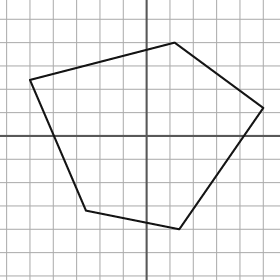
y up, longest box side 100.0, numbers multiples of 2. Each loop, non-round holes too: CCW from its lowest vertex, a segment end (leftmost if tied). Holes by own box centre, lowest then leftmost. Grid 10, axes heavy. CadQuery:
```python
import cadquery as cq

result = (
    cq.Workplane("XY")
    .moveTo(14.0, -40.0)
    .lineTo(50.0, 12.0)
    .lineTo(12.0, 40.0)
    .lineTo(-50.0, 24.0)
    .lineTo(-26.0, -32.0)
    .close()
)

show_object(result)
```